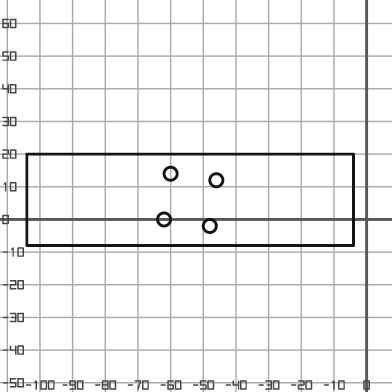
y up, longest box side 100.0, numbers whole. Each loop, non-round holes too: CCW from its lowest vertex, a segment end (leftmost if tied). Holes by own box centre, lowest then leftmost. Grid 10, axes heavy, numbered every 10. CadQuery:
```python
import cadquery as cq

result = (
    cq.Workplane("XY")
    .moveTo(-104.0, -8.0)
    .lineTo(-4.0, -8.0)
    .lineTo(-4.0, 20.0)
    .lineTo(-104.0, 20.0)
    .close()
    .moveTo(-48.0, -2.0)
    .circle(2.0)
    .moveTo(-62.0, 0.0)
    .circle(2.0)
    .moveTo(-46.0, 12.0)
    .circle(2.0)
    .moveTo(-60.0, 14.0)
    .circle(2.0)
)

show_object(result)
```